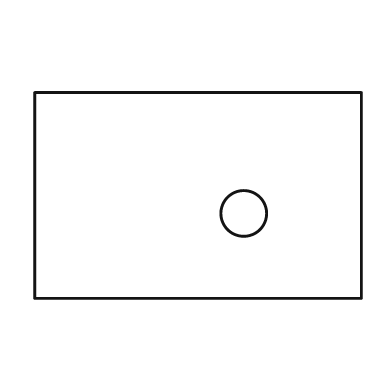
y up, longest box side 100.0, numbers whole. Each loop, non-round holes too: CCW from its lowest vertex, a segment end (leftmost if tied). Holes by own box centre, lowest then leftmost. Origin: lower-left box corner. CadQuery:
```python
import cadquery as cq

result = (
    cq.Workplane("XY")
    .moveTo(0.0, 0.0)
    .lineTo(100.0, 0.0)
    .lineTo(100.0, 63.0)
    .lineTo(0.0, 63.0)
    .close()
    .moveTo(64.0, 26.0)
    .circle(7.0)
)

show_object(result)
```